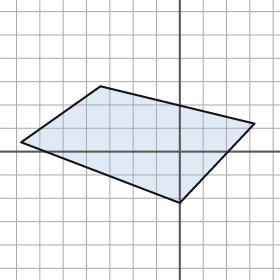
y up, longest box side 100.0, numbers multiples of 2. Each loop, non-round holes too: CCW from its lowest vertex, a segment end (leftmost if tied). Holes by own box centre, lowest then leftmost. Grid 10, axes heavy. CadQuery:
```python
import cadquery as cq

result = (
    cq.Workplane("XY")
    .moveTo(0.0, -22.0)
    .lineTo(32.0, 12.0)
    .lineTo(-34.0, 28.0)
    .lineTo(-68.0, 4.0)
    .close()
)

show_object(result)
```